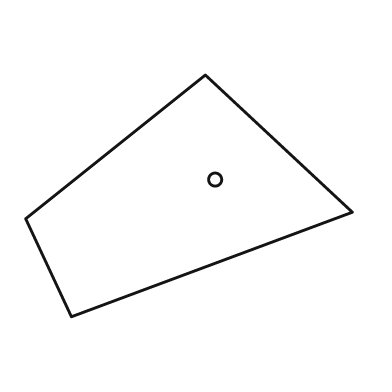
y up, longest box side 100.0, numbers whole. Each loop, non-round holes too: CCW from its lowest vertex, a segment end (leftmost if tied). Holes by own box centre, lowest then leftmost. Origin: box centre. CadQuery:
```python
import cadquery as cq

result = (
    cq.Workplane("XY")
    .moveTo(-36.0, -37.0)
    .lineTo(50.0, -5.0)
    .lineTo(5.0, 37.0)
    .lineTo(-50.0, -7.0)
    .close()
    .moveTo(8.0, 5.0)
    .circle(2.0)
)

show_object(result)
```